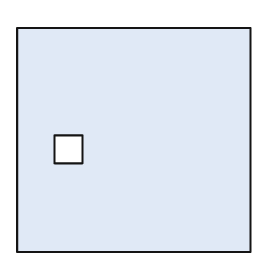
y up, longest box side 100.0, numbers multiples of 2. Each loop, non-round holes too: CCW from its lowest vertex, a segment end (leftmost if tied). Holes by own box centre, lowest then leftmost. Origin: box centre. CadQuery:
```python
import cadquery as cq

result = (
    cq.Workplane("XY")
    .moveTo(-50.0, -48.0)
    .lineTo(50.0, -48.0)
    .lineTo(50.0, 48.0)
    .lineTo(-50.0, 48.0)
    .close()
    .moveTo(-34.0, -10.0)
    .lineTo(-22.0, -10.0)
    .lineTo(-22.0, 2.0)
    .lineTo(-34.0, 2.0)
    .close()
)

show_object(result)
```